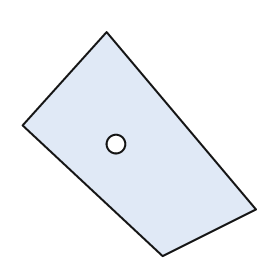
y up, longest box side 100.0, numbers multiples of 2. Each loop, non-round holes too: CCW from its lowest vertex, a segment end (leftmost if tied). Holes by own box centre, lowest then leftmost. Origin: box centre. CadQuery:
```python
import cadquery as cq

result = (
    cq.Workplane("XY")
    .moveTo(10.0, -48.0)
    .lineTo(50.0, -28.0)
    .lineTo(-14.0, 48.0)
    .lineTo(-50.0, 8.0)
    .close()
    .moveTo(-10.0, 0.0)
    .circle(4.0)
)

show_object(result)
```